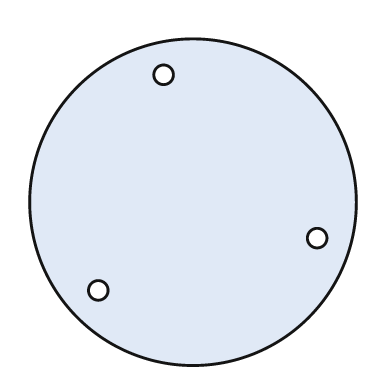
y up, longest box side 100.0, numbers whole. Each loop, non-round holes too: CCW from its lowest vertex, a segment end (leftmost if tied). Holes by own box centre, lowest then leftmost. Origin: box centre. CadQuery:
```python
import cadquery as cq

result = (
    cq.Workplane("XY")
    .moveTo(0.0, 0.0)
    .circle(50.0)
    .moveTo(-29.0, -27.0)
    .circle(3.0)
    .moveTo(38.0, -11.0)
    .circle(3.0)
    .moveTo(-9.0, 39.0)
    .circle(3.0)
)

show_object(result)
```